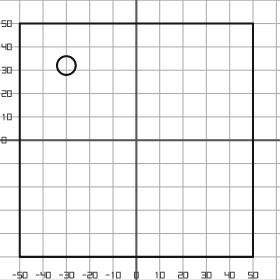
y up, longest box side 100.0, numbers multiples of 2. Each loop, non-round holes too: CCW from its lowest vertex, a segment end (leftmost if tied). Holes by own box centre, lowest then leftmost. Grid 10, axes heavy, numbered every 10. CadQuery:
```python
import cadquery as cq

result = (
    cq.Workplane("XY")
    .moveTo(-50.0, -50.0)
    .lineTo(50.0, -50.0)
    .lineTo(50.0, 50.0)
    .lineTo(-50.0, 50.0)
    .close()
    .moveTo(-30.0, 32.0)
    .circle(4.0)
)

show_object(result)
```